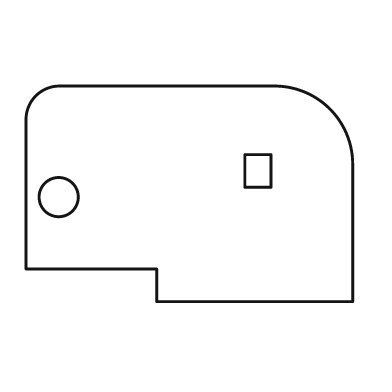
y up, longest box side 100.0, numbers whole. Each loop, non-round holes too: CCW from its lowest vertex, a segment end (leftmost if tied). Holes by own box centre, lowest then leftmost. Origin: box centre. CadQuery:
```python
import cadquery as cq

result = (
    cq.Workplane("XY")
    .moveTo(-10.0, -33.0)
    .lineTo(50.0, -33.0)
    .lineTo(50.0, 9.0)
    .threePointArc((43.0, 26.0), (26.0, 33.0))
    .lineTo(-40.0, 33.0)
    .threePointArc((-47.0, 30.0), (-50.0, 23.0))
    .lineTo(-50.0, -23.0)
    .lineTo(-10.0, -23.0)
    .close()
    .moveTo(-40.0, -1.0)
    .circle(6.0)
    .moveTo(17.0, 2.0)
    .lineTo(25.0, 2.0)
    .lineTo(25.0, 12.0)
    .lineTo(17.0, 12.0)
    .close()
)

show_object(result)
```